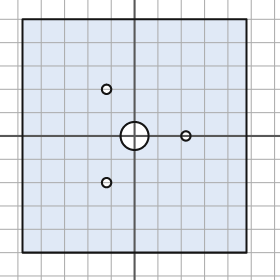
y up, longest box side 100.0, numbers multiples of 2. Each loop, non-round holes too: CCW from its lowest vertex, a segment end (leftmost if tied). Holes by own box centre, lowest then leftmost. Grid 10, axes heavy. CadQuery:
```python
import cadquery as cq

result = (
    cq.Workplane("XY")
    .moveTo(-48.0, -50.0)
    .lineTo(48.0, -50.0)
    .lineTo(48.0, 50.0)
    .lineTo(-48.0, 50.0)
    .close()
    .moveTo(-12.0, -20.0)
    .circle(2.0)
    .moveTo(0.0, 0.0)
    .circle(6.0)
    .moveTo(22.0, 0.0)
    .circle(2.0)
    .moveTo(-12.0, 20.0)
    .circle(2.0)
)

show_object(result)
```